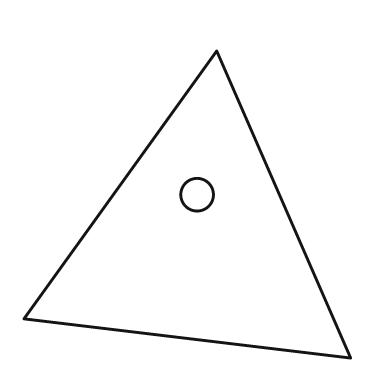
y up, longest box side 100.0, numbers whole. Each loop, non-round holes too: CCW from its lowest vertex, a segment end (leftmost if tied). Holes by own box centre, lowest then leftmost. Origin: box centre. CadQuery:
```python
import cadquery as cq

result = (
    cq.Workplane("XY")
    .moveTo(50.0, -47.0)
    .lineTo(9.0, 47.0)
    .lineTo(-50.0, -35.0)
    .close()
    .moveTo(3.0, 3.0)
    .circle(5.0)
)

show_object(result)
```